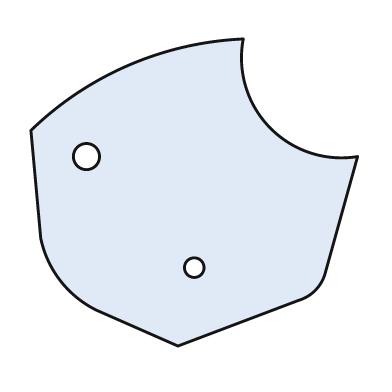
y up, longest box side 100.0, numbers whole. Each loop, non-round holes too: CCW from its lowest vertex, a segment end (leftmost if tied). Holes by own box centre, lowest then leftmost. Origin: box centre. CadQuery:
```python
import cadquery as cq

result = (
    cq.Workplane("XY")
    .moveTo(-5.0, -47.0)
    .lineTo(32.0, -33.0)
    .threePointArc((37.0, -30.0), (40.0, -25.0))
    .lineTo(50.0, 11.0)
    .threePointArc((23.0, 20.0), (15.0, 47.0))
    .threePointArc((-20.0, 39.0), (-50.0, 19.0))
    .lineTo(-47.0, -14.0)
    .threePointArc((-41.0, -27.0), (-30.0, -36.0))
    .close()
    .moveTo(0.0, -23.0)
    .circle(3.0)
    .moveTo(-33.0, 11.0)
    .circle(4.0)
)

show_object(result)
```